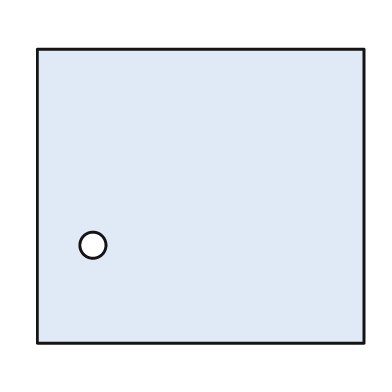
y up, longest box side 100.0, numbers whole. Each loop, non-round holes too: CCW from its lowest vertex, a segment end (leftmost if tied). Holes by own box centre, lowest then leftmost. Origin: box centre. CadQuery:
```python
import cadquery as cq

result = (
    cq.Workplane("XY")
    .moveTo(-50.0, -45.0)
    .lineTo(50.0, -45.0)
    .lineTo(50.0, 45.0)
    .lineTo(-50.0, 45.0)
    .close()
    .moveTo(-33.0, -15.0)
    .circle(4.0)
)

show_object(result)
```